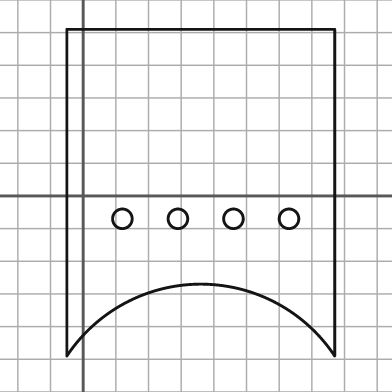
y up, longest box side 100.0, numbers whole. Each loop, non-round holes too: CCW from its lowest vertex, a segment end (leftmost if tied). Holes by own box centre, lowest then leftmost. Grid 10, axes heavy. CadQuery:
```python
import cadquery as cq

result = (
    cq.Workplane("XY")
    .moveTo(-5.0, -49.0)
    .threePointArc((36.0, -27.0), (77.0, -49.0))
    .lineTo(77.0, 51.0)
    .lineTo(-5.0, 51.0)
    .close()
    .moveTo(12.0, -7.0)
    .circle(3.0)
    .moveTo(29.0, -7.0)
    .circle(3.0)
    .moveTo(46.0, -7.0)
    .circle(3.0)
    .moveTo(63.0, -7.0)
    .circle(3.0)
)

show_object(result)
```